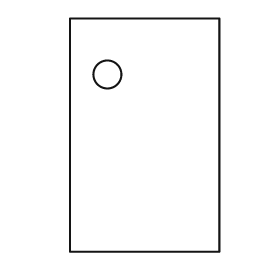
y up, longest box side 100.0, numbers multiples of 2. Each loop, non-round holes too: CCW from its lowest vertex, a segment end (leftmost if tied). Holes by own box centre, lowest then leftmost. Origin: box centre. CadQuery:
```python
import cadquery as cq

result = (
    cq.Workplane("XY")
    .moveTo(-32.0, -50.0)
    .lineTo(32.0, -50.0)
    .lineTo(32.0, 50.0)
    .lineTo(-32.0, 50.0)
    .close()
    .moveTo(-16.0, 26.0)
    .circle(6.0)
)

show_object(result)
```